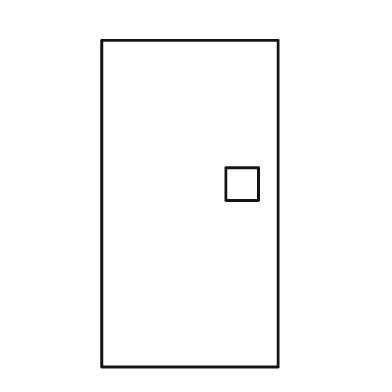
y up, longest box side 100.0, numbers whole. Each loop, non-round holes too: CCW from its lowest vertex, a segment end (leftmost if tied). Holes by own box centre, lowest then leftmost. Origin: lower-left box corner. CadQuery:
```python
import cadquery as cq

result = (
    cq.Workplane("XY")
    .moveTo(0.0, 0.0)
    .lineTo(54.0, 0.0)
    .lineTo(54.0, 100.0)
    .lineTo(0.0, 100.0)
    .close()
    .moveTo(38.0, 51.0)
    .lineTo(48.0, 51.0)
    .lineTo(48.0, 61.0)
    .lineTo(38.0, 61.0)
    .close()
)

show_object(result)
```